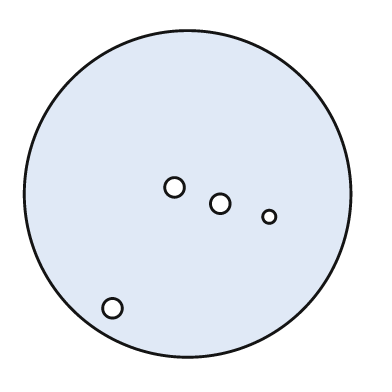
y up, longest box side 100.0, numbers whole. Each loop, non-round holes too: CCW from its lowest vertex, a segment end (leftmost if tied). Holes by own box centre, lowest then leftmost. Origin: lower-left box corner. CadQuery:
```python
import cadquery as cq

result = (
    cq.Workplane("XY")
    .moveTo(50.0, 50.0)
    .circle(50.0)
    .moveTo(27.0, 15.0)
    .circle(3.0)
    .moveTo(75.0, 43.0)
    .circle(2.0)
    .moveTo(60.0, 47.0)
    .circle(3.0)
    .moveTo(46.0, 52.0)
    .circle(3.0)
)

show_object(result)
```